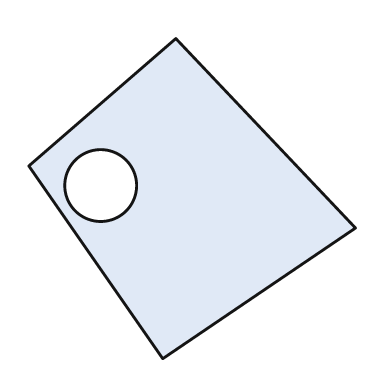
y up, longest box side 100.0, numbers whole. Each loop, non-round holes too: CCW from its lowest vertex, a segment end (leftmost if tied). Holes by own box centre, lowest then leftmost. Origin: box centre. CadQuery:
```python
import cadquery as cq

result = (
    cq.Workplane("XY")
    .moveTo(-9.0, -49.0)
    .lineTo(50.0, -9.0)
    .lineTo(-5.0, 49.0)
    .lineTo(-50.0, 10.0)
    .close()
    .moveTo(-28.0, 4.0)
    .circle(11.0)
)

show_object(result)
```